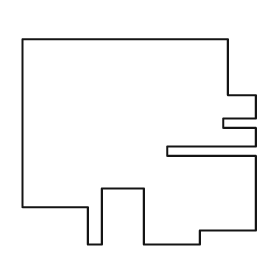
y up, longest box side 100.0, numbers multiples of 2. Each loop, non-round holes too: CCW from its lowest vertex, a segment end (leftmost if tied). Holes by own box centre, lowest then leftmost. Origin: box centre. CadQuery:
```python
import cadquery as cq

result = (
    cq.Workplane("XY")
    .moveTo(-22.0, -44.0)
    .lineTo(-16.0, -44.0)
    .lineTo(-16.0, -20.0)
    .lineTo(2.0, -20.0)
    .lineTo(2.0, -44.0)
    .lineTo(26.0, -44.0)
    .lineTo(26.0, -38.0)
    .lineTo(50.0, -38.0)
    .lineTo(50.0, -6.0)
    .lineTo(12.0, -6.0)
    .lineTo(12.0, -2.0)
    .lineTo(50.0, -2.0)
    .lineTo(50.0, 6.0)
    .lineTo(36.0, 6.0)
    .lineTo(36.0, 10.0)
    .lineTo(50.0, 10.0)
    .lineTo(50.0, 20.0)
    .lineTo(38.0, 20.0)
    .lineTo(38.0, 44.0)
    .lineTo(-50.0, 44.0)
    .lineTo(-50.0, -28.0)
    .lineTo(-22.0, -28.0)
    .close()
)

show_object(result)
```